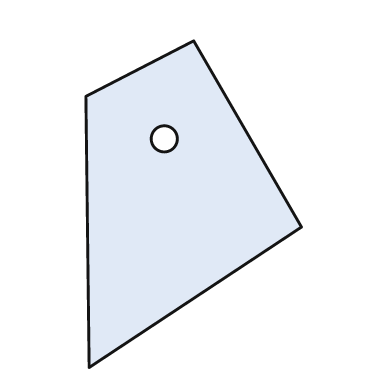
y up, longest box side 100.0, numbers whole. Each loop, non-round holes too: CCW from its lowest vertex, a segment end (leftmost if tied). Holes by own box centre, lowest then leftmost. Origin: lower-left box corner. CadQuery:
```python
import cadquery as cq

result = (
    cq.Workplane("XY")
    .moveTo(1.0, 0.0)
    .lineTo(66.0, 43.0)
    .lineTo(33.0, 100.0)
    .lineTo(0.0, 83.0)
    .close()
    .moveTo(24.0, 70.0)
    .circle(4.0)
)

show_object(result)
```